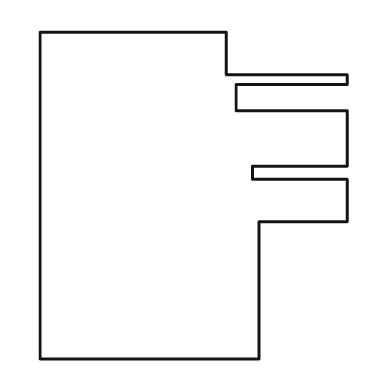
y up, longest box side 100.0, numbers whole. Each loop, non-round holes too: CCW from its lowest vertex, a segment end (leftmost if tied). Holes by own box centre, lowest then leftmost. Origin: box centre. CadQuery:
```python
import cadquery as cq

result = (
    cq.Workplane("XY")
    .moveTo(-47.0, -50.0)
    .lineTo(20.0, -50.0)
    .lineTo(20.0, -8.0)
    .lineTo(47.0, -8.0)
    .lineTo(47.0, 5.0)
    .lineTo(18.0, 5.0)
    .lineTo(18.0, 9.0)
    .lineTo(47.0, 9.0)
    .lineTo(47.0, 26.0)
    .lineTo(13.0, 26.0)
    .lineTo(13.0, 34.0)
    .lineTo(47.0, 34.0)
    .lineTo(47.0, 37.0)
    .lineTo(10.0, 37.0)
    .lineTo(10.0, 50.0)
    .lineTo(-47.0, 50.0)
    .close()
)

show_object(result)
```